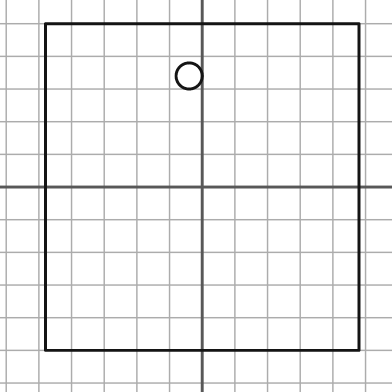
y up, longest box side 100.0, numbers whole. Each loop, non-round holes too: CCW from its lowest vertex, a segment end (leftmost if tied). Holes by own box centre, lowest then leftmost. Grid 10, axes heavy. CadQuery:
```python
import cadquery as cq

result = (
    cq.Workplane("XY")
    .moveTo(-48.0, -50.0)
    .lineTo(48.0, -50.0)
    .lineTo(48.0, 50.0)
    .lineTo(-48.0, 50.0)
    .close()
    .moveTo(-4.0, 34.0)
    .circle(4.0)
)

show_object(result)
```